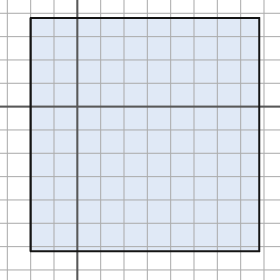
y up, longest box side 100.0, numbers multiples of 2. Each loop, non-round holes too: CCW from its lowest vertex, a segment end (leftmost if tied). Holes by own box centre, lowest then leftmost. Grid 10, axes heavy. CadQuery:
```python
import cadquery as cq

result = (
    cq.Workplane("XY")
    .moveTo(-20.0, -62.0)
    .lineTo(78.0, -62.0)
    .lineTo(78.0, 38.0)
    .lineTo(-20.0, 38.0)
    .close()
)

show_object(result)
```